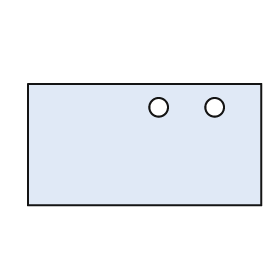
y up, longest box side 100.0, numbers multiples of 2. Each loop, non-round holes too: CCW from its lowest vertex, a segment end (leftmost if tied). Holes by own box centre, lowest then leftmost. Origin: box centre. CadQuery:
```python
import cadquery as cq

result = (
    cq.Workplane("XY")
    .moveTo(-50.0, -26.0)
    .lineTo(50.0, -26.0)
    .lineTo(50.0, 26.0)
    .lineTo(-50.0, 26.0)
    .close()
    .moveTo(6.0, 16.0)
    .circle(4.0)
    .moveTo(30.0, 16.0)
    .circle(4.0)
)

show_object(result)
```